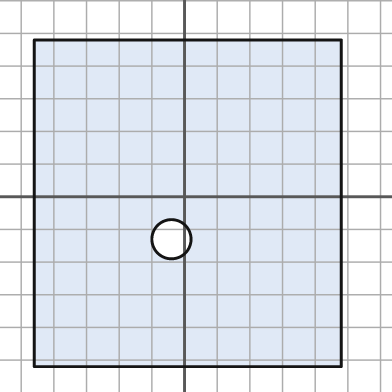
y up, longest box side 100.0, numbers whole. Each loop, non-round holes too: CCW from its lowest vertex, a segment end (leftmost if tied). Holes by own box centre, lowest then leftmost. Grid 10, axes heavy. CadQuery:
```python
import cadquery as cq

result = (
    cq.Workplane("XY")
    .moveTo(-46.0, -52.0)
    .lineTo(48.0, -52.0)
    .lineTo(48.0, 48.0)
    .lineTo(-46.0, 48.0)
    .close()
    .moveTo(-4.0, -13.0)
    .circle(6.0)
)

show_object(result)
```